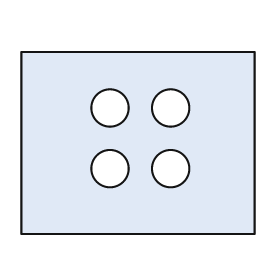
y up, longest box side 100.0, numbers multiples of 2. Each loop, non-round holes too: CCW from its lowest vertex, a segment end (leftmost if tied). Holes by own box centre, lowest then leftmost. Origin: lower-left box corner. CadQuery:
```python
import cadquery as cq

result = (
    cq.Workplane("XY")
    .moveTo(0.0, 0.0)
    .lineTo(100.0, 0.0)
    .lineTo(100.0, 78.0)
    .lineTo(0.0, 78.0)
    .close()
    .moveTo(38.0, 28.0)
    .circle(8.0)
    .moveTo(64.0, 28.0)
    .circle(8.0)
    .moveTo(38.0, 54.0)
    .circle(8.0)
    .moveTo(64.0, 54.0)
    .circle(8.0)
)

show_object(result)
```